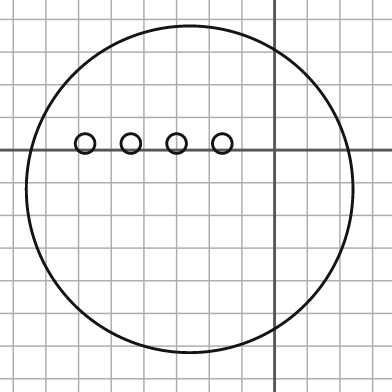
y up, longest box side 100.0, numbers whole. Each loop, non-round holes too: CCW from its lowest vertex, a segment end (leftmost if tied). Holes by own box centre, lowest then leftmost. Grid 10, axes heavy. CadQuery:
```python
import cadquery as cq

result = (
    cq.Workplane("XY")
    .moveTo(-26.0, -12.0)
    .circle(50.0)
    .moveTo(-58.0, 2.0)
    .circle(3.0)
    .moveTo(-44.0, 2.0)
    .circle(3.0)
    .moveTo(-30.0, 2.0)
    .circle(3.0)
    .moveTo(-16.0, 2.0)
    .circle(3.0)
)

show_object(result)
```